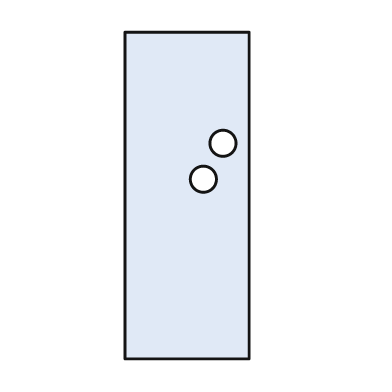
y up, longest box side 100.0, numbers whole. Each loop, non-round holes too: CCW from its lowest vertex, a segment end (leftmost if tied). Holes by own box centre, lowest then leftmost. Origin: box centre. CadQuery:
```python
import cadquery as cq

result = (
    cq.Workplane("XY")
    .moveTo(-19.0, -50.0)
    .lineTo(19.0, -50.0)
    .lineTo(19.0, 50.0)
    .lineTo(-19.0, 50.0)
    .close()
    .moveTo(5.0, 5.0)
    .circle(4.0)
    .moveTo(11.0, 16.0)
    .circle(4.0)
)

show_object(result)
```